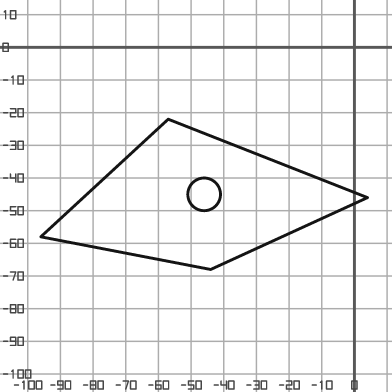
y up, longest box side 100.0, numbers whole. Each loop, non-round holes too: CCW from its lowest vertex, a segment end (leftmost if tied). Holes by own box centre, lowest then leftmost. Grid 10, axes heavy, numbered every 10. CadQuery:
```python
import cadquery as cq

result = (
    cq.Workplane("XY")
    .moveTo(-44.0, -68.0)
    .lineTo(4.0, -46.0)
    .lineTo(-57.0, -22.0)
    .lineTo(-96.0, -58.0)
    .close()
    .moveTo(-46.0, -45.0)
    .circle(5.0)
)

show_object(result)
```